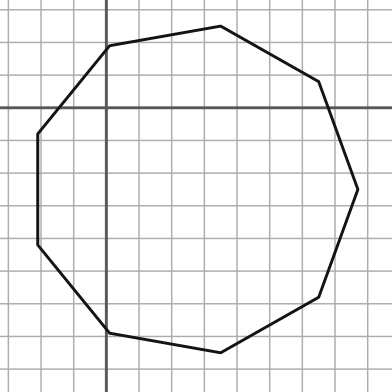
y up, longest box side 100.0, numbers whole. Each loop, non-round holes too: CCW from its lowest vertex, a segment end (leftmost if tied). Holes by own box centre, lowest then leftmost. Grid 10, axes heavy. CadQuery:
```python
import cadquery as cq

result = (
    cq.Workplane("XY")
    .moveTo(35.0, -75.0)
    .lineTo(65.0, -58.0)
    .lineTo(77.0, -25.0)
    .lineTo(65.0, 8.0)
    .lineTo(35.0, 25.0)
    .lineTo(1.0, 19.0)
    .lineTo(-21.0, -8.0)
    .lineTo(-21.0, -42.0)
    .lineTo(1.0, -69.0)
    .close()
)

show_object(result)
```